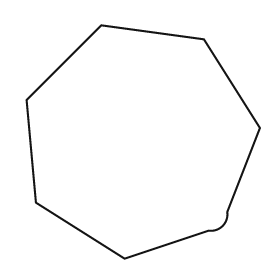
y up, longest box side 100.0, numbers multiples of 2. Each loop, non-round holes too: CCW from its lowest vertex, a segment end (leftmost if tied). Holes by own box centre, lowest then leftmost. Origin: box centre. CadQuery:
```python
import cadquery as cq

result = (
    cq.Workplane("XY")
    .moveTo(-8.0, -50.0)
    .lineTo(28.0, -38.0)
    .threePointArc((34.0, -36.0), (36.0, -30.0))
    .lineTo(50.0, 6.0)
    .lineTo(26.0, 44.0)
    .lineTo(-18.0, 50.0)
    .lineTo(-50.0, 18.0)
    .lineTo(-46.0, -26.0)
    .close()
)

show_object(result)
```